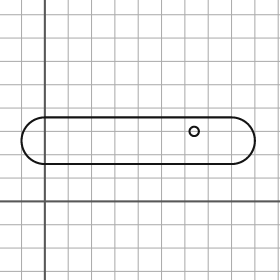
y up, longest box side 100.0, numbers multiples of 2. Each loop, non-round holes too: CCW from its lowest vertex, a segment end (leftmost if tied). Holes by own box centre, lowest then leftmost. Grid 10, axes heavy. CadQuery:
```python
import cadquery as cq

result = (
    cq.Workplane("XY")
    .moveTo(0.0, 16.0)
    .lineTo(80.0, 16.0)
    .threePointArc((90.0, 26.0), (80.0, 36.0))
    .lineTo(0.0, 36.0)
    .threePointArc((-10.0, 26.0), (0.0, 16.0))
    .close()
    .moveTo(64.0, 30.0)
    .circle(2.0)
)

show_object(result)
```